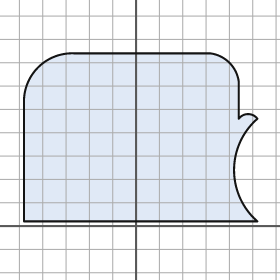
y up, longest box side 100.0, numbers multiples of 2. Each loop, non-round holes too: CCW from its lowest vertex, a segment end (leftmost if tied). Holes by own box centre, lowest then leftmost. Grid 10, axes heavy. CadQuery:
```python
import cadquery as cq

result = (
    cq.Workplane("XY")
    .moveTo(-48.0, 2.0)
    .lineTo(52.0, 2.0)
    .threePointArc((42.0, 24.0), (52.0, 46.0))
    .threePointArc((48.0, 48.0), (44.0, 46.0))
    .lineTo(44.0, 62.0)
    .threePointArc((40.0, 70.0), (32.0, 74.0))
    .lineTo(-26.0, 74.0)
    .threePointArc((-42.0, 68.0), (-48.0, 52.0))
    .close()
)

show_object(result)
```